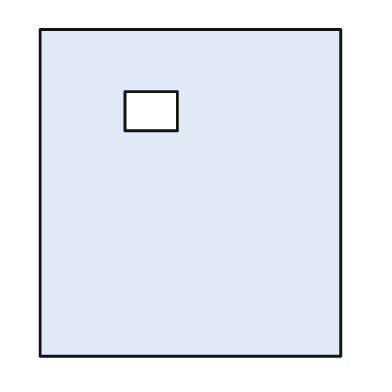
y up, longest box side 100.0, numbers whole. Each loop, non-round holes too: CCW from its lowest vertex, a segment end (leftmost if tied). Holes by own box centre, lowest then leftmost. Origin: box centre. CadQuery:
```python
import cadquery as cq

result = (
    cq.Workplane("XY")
    .moveTo(-46.0, -50.0)
    .lineTo(46.0, -50.0)
    .lineTo(46.0, 50.0)
    .lineTo(-46.0, 50.0)
    .close()
    .moveTo(-20.0, 19.0)
    .lineTo(-4.0, 19.0)
    .lineTo(-4.0, 31.0)
    .lineTo(-20.0, 31.0)
    .close()
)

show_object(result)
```